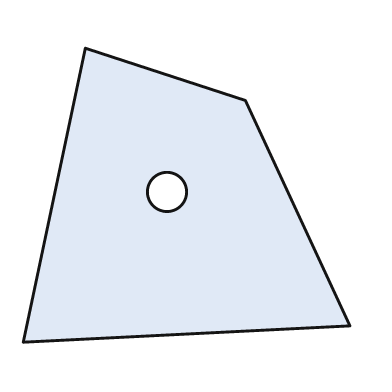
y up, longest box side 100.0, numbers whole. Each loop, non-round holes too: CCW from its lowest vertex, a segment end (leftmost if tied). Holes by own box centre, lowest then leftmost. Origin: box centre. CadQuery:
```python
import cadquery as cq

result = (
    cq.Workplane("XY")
    .moveTo(-50.0, -45.0)
    .lineTo(50.0, -40.0)
    .lineTo(18.0, 29.0)
    .lineTo(-31.0, 45.0)
    .close()
    .moveTo(-6.0, 1.0)
    .circle(6.0)
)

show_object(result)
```